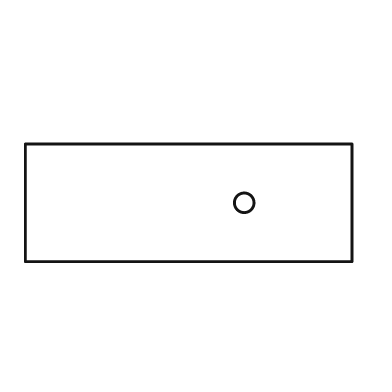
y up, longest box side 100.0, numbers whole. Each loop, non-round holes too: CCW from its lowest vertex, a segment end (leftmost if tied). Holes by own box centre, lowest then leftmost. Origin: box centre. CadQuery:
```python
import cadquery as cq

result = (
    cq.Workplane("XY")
    .moveTo(-50.0, -18.0)
    .lineTo(50.0, -18.0)
    .lineTo(50.0, 18.0)
    .lineTo(-50.0, 18.0)
    .close()
    .moveTo(17.0, 0.0)
    .circle(3.0)
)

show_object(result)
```